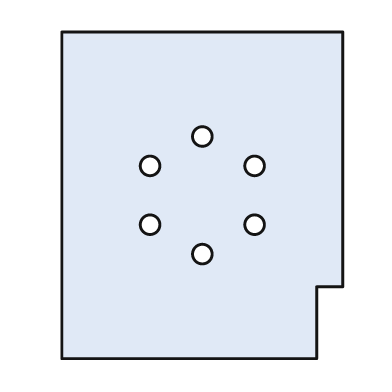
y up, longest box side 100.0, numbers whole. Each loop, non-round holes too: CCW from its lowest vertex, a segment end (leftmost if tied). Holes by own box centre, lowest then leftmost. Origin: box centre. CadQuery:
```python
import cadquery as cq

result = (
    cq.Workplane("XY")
    .moveTo(-43.0, -50.0)
    .lineTo(35.0, -50.0)
    .lineTo(35.0, -28.0)
    .lineTo(43.0, -28.0)
    .lineTo(43.0, 50.0)
    .lineTo(-43.0, 50.0)
    .close()
    .moveTo(0.0, -18.0)
    .circle(3.0)
    .moveTo(-16.0, -9.0)
    .circle(3.0)
    .moveTo(16.0, -9.0)
    .circle(3.0)
    .moveTo(-16.0, 9.0)
    .circle(3.0)
    .moveTo(16.0, 9.0)
    .circle(3.0)
    .moveTo(0.0, 18.0)
    .circle(3.0)
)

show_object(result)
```